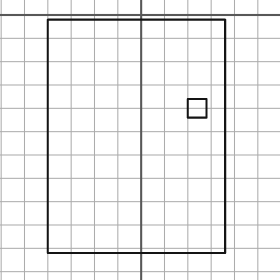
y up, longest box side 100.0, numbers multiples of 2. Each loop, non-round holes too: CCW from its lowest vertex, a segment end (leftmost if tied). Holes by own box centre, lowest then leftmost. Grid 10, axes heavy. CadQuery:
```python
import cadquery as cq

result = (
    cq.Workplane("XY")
    .moveTo(-40.0, -102.0)
    .lineTo(36.0, -102.0)
    .lineTo(36.0, -2.0)
    .lineTo(-40.0, -2.0)
    .close()
    .moveTo(20.0, -44.0)
    .lineTo(28.0, -44.0)
    .lineTo(28.0, -36.0)
    .lineTo(20.0, -36.0)
    .close()
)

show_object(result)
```